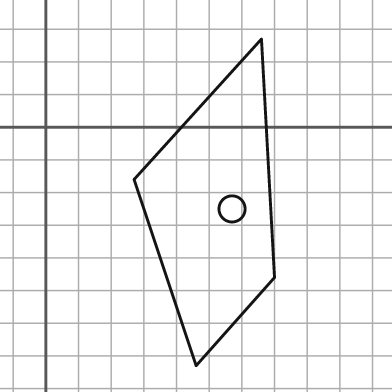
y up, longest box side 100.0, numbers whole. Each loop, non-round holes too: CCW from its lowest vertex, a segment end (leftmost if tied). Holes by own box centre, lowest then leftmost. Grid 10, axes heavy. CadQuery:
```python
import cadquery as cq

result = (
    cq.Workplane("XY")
    .moveTo(46.0, -73.0)
    .lineTo(70.0, -46.0)
    .lineTo(66.0, 27.0)
    .lineTo(27.0, -16.0)
    .close()
    .moveTo(57.0, -25.0)
    .circle(4.0)
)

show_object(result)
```